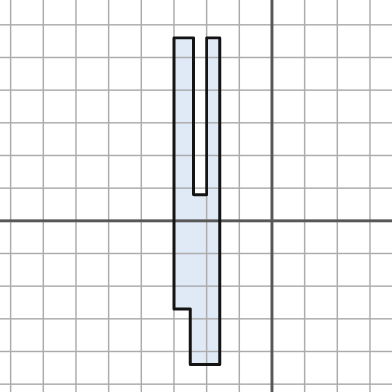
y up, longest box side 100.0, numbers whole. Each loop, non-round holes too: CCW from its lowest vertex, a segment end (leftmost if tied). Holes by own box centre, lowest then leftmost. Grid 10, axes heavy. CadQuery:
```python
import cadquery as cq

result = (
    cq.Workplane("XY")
    .moveTo(-25.0, -44.0)
    .lineTo(-16.0, -44.0)
    .lineTo(-16.0, 56.0)
    .lineTo(-20.0, 56.0)
    .lineTo(-20.0, 8.0)
    .lineTo(-24.0, 8.0)
    .lineTo(-24.0, 56.0)
    .lineTo(-30.0, 56.0)
    .lineTo(-30.0, -27.0)
    .lineTo(-25.0, -27.0)
    .close()
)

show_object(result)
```